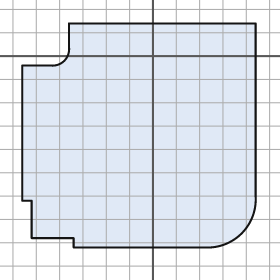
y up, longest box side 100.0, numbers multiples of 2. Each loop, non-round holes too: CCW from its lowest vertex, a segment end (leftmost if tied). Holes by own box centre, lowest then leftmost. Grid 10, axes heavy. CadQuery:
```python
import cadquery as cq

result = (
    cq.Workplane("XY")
    .moveTo(-34.0, -82.0)
    .lineTo(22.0, -82.0)
    .threePointArc((38.0, -76.0), (44.0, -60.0))
    .lineTo(44.0, 14.0)
    .lineTo(-36.0, 14.0)
    .lineTo(-36.0, 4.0)
    .threePointArc((-38.0, -2.0), (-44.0, -4.0))
    .lineTo(-56.0, -4.0)
    .lineTo(-56.0, -62.0)
    .lineTo(-52.0, -62.0)
    .lineTo(-52.0, -78.0)
    .lineTo(-34.0, -78.0)
    .close()
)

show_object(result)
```